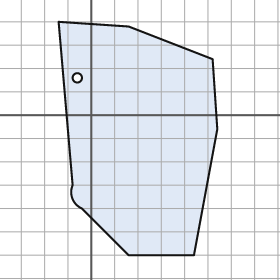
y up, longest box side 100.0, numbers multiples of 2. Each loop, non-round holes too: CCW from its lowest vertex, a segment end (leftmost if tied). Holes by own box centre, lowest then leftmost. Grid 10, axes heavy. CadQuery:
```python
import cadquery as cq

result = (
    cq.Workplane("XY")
    .moveTo(16.0, -60.0)
    .lineTo(44.0, -60.0)
    .lineTo(54.0, -6.0)
    .lineTo(52.0, 24.0)
    .lineTo(16.0, 38.0)
    .lineTo(-14.0, 40.0)
    .lineTo(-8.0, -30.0)
    .threePointArc((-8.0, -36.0), (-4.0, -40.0))
    .close()
    .moveTo(-6.0, 16.0)
    .circle(2.0)
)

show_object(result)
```